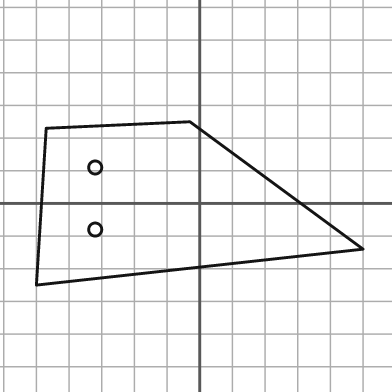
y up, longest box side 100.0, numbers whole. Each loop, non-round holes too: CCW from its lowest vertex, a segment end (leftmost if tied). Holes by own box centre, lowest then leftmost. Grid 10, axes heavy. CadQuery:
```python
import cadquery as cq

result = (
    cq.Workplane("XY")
    .moveTo(-50.0, -25.0)
    .lineTo(50.0, -14.0)
    .lineTo(-3.0, 25.0)
    .lineTo(-47.0, 23.0)
    .close()
    .moveTo(-32.0, -8.0)
    .circle(2.0)
    .moveTo(-32.0, 11.0)
    .circle(2.0)
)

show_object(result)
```